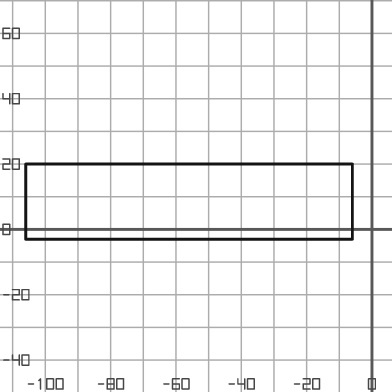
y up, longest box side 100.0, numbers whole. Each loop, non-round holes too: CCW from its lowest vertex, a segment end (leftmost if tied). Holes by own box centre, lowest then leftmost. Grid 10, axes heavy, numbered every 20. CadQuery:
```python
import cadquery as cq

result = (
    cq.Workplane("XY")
    .moveTo(-106.0, -3.0)
    .lineTo(-6.0, -3.0)
    .lineTo(-6.0, 20.0)
    .lineTo(-106.0, 20.0)
    .close()
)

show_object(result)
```